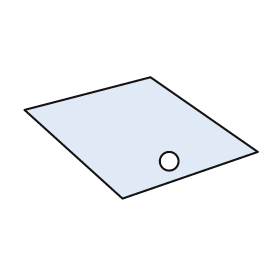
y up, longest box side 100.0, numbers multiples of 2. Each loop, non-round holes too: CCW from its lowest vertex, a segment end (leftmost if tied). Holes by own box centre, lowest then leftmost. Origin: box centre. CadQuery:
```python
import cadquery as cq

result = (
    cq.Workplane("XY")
    .moveTo(-8.0, -26.0)
    .lineTo(50.0, -6.0)
    .lineTo(4.0, 26.0)
    .lineTo(-50.0, 12.0)
    .close()
    .moveTo(12.0, -10.0)
    .circle(4.0)
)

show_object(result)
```